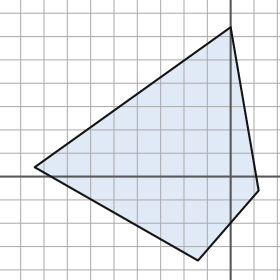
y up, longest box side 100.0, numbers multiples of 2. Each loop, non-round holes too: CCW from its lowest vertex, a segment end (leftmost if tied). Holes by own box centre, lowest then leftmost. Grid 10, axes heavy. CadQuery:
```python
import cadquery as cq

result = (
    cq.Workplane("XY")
    .moveTo(-14.0, -36.0)
    .lineTo(12.0, -6.0)
    .lineTo(0.0, 64.0)
    .lineTo(-84.0, 4.0)
    .close()
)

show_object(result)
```